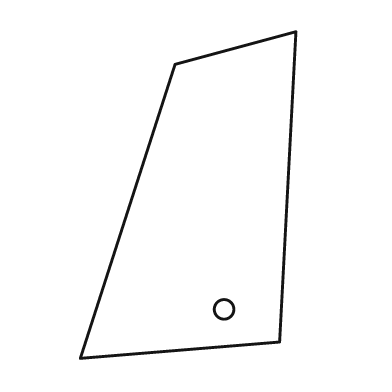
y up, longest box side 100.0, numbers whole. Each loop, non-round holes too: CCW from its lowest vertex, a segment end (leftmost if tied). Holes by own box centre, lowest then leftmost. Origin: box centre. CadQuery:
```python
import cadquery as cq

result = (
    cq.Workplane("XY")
    .moveTo(-33.0, -50.0)
    .lineTo(28.0, -45.0)
    .lineTo(33.0, 50.0)
    .lineTo(-4.0, 40.0)
    .close()
    .moveTo(11.0, -35.0)
    .circle(3.0)
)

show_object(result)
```